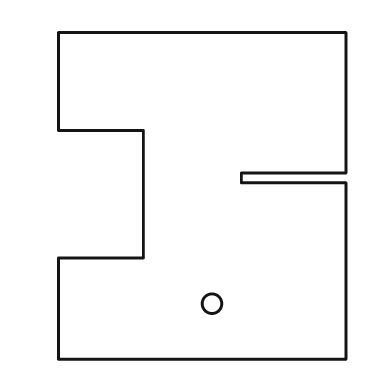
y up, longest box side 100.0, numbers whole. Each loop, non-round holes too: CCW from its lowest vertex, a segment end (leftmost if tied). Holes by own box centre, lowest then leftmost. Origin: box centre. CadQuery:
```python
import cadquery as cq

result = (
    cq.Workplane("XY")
    .moveTo(-44.0, -50.0)
    .lineTo(44.0, -50.0)
    .lineTo(44.0, 4.0)
    .lineTo(12.0, 4.0)
    .lineTo(12.0, 7.0)
    .lineTo(44.0, 7.0)
    .lineTo(44.0, 50.0)
    .lineTo(-44.0, 50.0)
    .lineTo(-44.0, 20.0)
    .lineTo(-18.0, 20.0)
    .lineTo(-18.0, -19.0)
    .lineTo(-44.0, -19.0)
    .close()
    .moveTo(3.0, -33.0)
    .circle(3.0)
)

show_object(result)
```